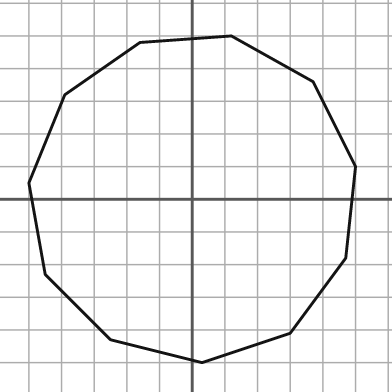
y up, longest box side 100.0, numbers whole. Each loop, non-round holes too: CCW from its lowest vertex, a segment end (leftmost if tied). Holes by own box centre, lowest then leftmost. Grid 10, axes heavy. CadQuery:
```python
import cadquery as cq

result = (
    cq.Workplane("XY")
    .moveTo(3.0, -50.0)
    .lineTo(30.0, -41.0)
    .lineTo(47.0, -18.0)
    .lineTo(50.0, 10.0)
    .lineTo(37.0, 36.0)
    .lineTo(12.0, 50.0)
    .lineTo(-16.0, 48.0)
    .lineTo(-39.0, 32.0)
    .lineTo(-50.0, 5.0)
    .lineTo(-45.0, -23.0)
    .lineTo(-25.0, -43.0)
    .close()
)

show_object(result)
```